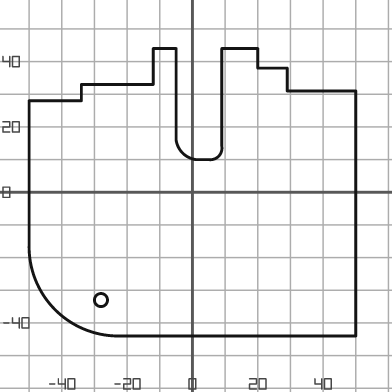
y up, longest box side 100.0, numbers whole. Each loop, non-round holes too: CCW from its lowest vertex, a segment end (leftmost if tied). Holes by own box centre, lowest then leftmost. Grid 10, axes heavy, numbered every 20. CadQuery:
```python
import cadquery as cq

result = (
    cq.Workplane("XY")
    .moveTo(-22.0, -44.0)
    .lineTo(50.0, -44.0)
    .lineTo(50.0, 31.0)
    .lineTo(29.0, 31.0)
    .lineTo(29.0, 38.0)
    .lineTo(20.0, 38.0)
    .lineTo(20.0, 44.0)
    .lineTo(9.0, 44.0)
    .lineTo(9.0, 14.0)
    .threePointArc((8.0, 11.0), (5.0, 10.0))
    .lineTo(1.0, 10.0)
    .threePointArc((-3.0, 12.0), (-5.0, 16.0))
    .lineTo(-5.0, 44.0)
    .lineTo(-12.0, 44.0)
    .lineTo(-12.0, 33.0)
    .lineTo(-34.0, 33.0)
    .lineTo(-34.0, 28.0)
    .lineTo(-50.0, 28.0)
    .lineTo(-50.0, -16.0)
    .threePointArc((-42.0, -36.0), (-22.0, -44.0))
    .close()
    .moveTo(-28.0, -33.0)
    .circle(2.0)
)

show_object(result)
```